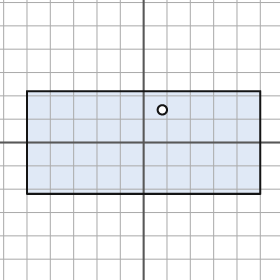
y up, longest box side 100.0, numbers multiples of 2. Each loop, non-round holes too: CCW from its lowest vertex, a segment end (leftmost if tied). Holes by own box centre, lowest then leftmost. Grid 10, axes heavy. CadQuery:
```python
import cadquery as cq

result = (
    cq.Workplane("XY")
    .moveTo(-50.0, -22.0)
    .lineTo(50.0, -22.0)
    .lineTo(50.0, 22.0)
    .lineTo(-50.0, 22.0)
    .close()
    .moveTo(8.0, 14.0)
    .circle(2.0)
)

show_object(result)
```